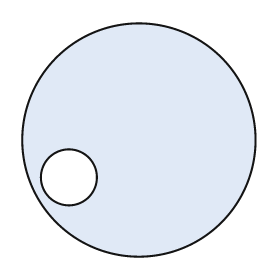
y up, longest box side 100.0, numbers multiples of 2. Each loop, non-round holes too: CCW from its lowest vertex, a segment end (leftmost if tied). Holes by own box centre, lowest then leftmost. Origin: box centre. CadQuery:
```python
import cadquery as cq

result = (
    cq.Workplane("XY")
    .moveTo(0.0, 0.0)
    .circle(50.0)
    .moveTo(-30.0, -16.0)
    .circle(12.0)
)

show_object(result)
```